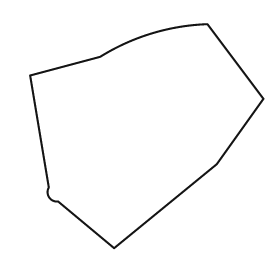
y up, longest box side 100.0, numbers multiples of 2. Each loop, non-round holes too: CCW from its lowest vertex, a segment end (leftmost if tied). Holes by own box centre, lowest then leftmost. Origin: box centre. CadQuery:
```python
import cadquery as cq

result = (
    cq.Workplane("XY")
    .moveTo(-14.0, -48.0)
    .lineTo(30.0, -12.0)
    .lineTo(50.0, 16.0)
    .lineTo(26.0, 48.0)
    .threePointArc((2.0, 44.0), (-20.0, 34.0))
    .lineTo(-50.0, 26.0)
    .lineTo(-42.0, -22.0)
    .threePointArc((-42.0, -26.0), (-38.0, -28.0))
    .close()
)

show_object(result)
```